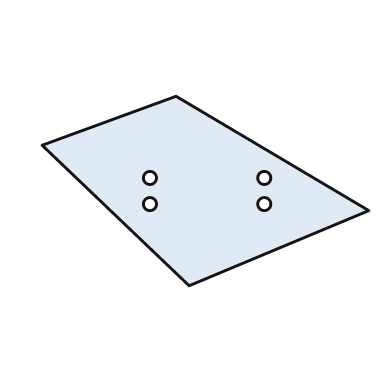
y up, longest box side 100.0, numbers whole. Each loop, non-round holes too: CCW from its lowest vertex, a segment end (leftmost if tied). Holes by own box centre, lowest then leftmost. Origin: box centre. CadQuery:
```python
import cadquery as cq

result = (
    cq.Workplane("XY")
    .moveTo(-5.0, -29.0)
    .lineTo(50.0, -6.0)
    .lineTo(-9.0, 29.0)
    .lineTo(-50.0, 14.0)
    .close()
    .moveTo(-17.0, -4.0)
    .circle(2.0)
    .moveTo(18.0, -4.0)
    .circle(2.0)
    .moveTo(-17.0, 4.0)
    .circle(2.0)
    .moveTo(18.0, 4.0)
    .circle(2.0)
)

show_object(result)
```